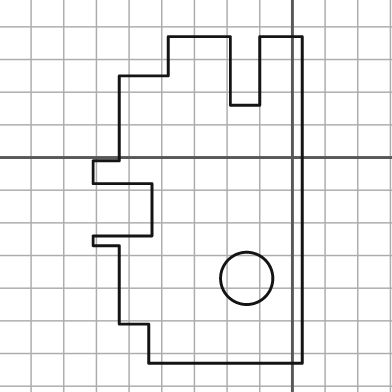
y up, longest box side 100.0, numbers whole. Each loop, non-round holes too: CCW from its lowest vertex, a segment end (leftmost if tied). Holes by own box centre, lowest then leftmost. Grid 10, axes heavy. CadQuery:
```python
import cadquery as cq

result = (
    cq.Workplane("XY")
    .moveTo(-44.0, -63.0)
    .lineTo(3.0, -63.0)
    .lineTo(3.0, 37.0)
    .lineTo(-10.0, 37.0)
    .lineTo(-10.0, 16.0)
    .lineTo(-19.0, 16.0)
    .lineTo(-19.0, 37.0)
    .lineTo(-38.0, 37.0)
    .lineTo(-38.0, 25.0)
    .lineTo(-53.0, 25.0)
    .lineTo(-53.0, -1.0)
    .lineTo(-61.0, -1.0)
    .lineTo(-61.0, -8.0)
    .lineTo(-43.0, -8.0)
    .lineTo(-43.0, -24.0)
    .lineTo(-61.0, -24.0)
    .lineTo(-61.0, -27.0)
    .lineTo(-53.0, -27.0)
    .lineTo(-53.0, -51.0)
    .lineTo(-44.0, -51.0)
    .close()
    .moveTo(-14.0, -37.0)
    .circle(8.0)
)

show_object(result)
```